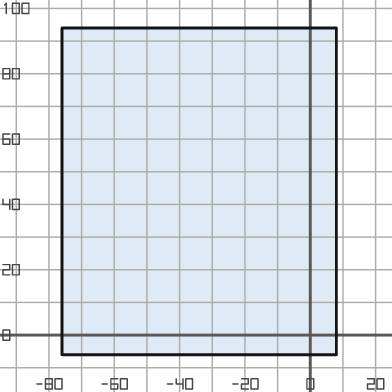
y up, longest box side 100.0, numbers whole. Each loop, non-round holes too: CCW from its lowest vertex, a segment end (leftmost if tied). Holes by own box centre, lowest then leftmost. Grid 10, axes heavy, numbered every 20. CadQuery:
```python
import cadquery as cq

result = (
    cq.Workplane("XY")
    .moveTo(-76.0, -6.0)
    .lineTo(8.0, -6.0)
    .lineTo(8.0, 94.0)
    .lineTo(-76.0, 94.0)
    .close()
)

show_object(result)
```